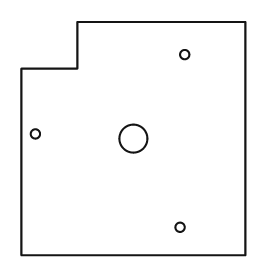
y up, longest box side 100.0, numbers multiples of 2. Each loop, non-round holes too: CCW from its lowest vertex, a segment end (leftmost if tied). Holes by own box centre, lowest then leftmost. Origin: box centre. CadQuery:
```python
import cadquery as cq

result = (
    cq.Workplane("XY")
    .moveTo(-48.0, -50.0)
    .lineTo(48.0, -50.0)
    .lineTo(48.0, 50.0)
    .lineTo(-24.0, 50.0)
    .lineTo(-24.0, 30.0)
    .lineTo(-48.0, 30.0)
    .close()
    .moveTo(20.0, -38.0)
    .circle(2.0)
    .moveTo(0.0, 0.0)
    .circle(6.0)
    .moveTo(-42.0, 2.0)
    .circle(2.0)
    .moveTo(22.0, 36.0)
    .circle(2.0)
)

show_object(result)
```